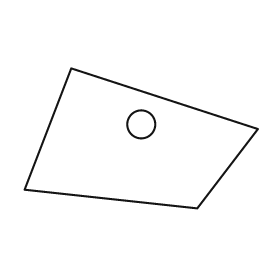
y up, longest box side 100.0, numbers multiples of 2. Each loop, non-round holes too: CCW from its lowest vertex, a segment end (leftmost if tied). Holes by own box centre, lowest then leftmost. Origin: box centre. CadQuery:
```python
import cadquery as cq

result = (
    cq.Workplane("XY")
    .moveTo(24.0, -30.0)
    .lineTo(50.0, 4.0)
    .lineTo(-30.0, 30.0)
    .lineTo(-50.0, -22.0)
    .close()
    .moveTo(0.0, 6.0)
    .circle(6.0)
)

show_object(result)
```